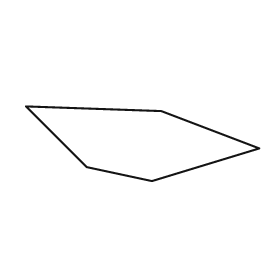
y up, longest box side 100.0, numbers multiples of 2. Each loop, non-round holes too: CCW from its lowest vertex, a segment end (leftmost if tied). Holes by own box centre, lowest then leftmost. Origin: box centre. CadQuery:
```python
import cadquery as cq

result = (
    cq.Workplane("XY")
    .moveTo(4.0, -16.0)
    .lineTo(50.0, -2.0)
    .lineTo(8.0, 14.0)
    .lineTo(-50.0, 16.0)
    .lineTo(-24.0, -10.0)
    .close()
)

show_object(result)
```